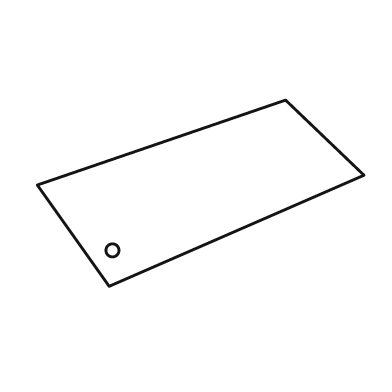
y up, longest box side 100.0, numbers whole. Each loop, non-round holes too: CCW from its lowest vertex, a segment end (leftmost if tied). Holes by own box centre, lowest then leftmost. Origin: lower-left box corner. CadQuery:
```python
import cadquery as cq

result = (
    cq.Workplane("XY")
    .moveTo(22.0, 0.0)
    .lineTo(100.0, 34.0)
    .lineTo(76.0, 57.0)
    .lineTo(0.0, 31.0)
    .close()
    .moveTo(23.0, 11.0)
    .circle(2.0)
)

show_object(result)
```